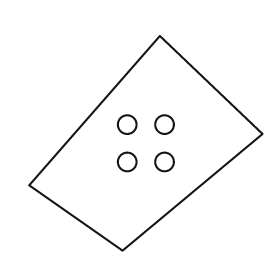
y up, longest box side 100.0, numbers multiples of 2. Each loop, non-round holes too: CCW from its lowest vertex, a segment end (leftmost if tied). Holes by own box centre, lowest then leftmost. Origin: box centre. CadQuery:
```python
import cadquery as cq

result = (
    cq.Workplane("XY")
    .moveTo(-10.0, -46.0)
    .lineTo(50.0, 4.0)
    .lineTo(6.0, 46.0)
    .lineTo(-50.0, -18.0)
    .close()
    .moveTo(-8.0, -8.0)
    .circle(4.0)
    .moveTo(8.0, -8.0)
    .circle(4.0)
    .moveTo(-8.0, 8.0)
    .circle(4.0)
    .moveTo(8.0, 8.0)
    .circle(4.0)
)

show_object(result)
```